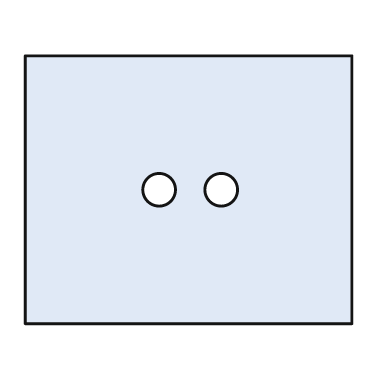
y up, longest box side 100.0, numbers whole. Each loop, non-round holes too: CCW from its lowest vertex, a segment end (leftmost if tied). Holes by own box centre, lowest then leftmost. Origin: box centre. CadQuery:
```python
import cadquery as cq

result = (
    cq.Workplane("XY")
    .moveTo(-50.0, -41.0)
    .lineTo(50.0, -41.0)
    .lineTo(50.0, 41.0)
    .lineTo(-50.0, 41.0)
    .close()
    .moveTo(-9.0, 0.0)
    .circle(5.0)
    .moveTo(10.0, 0.0)
    .circle(5.0)
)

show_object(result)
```